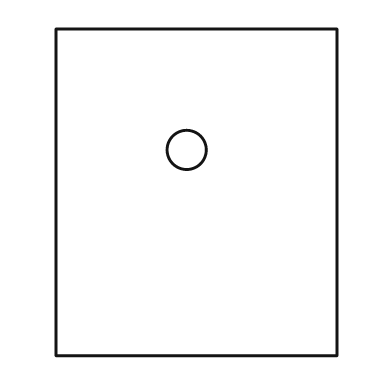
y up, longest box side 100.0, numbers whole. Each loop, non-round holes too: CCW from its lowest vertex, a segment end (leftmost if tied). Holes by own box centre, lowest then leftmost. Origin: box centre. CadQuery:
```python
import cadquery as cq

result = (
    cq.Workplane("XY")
    .moveTo(-43.0, -50.0)
    .lineTo(43.0, -50.0)
    .lineTo(43.0, 50.0)
    .lineTo(-43.0, 50.0)
    .close()
    .moveTo(-3.0, 13.0)
    .circle(6.0)
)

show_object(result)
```